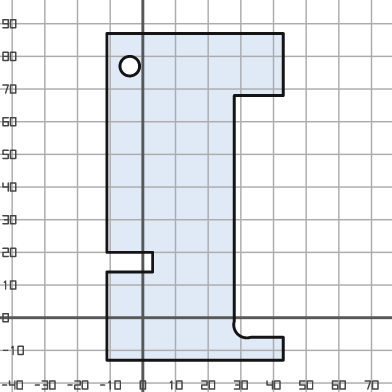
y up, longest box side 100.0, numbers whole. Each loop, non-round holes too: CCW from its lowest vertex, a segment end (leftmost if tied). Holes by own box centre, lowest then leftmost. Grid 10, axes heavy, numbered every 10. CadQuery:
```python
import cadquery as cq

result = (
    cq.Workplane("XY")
    .moveTo(-11.0, -13.0)
    .lineTo(43.0, -13.0)
    .lineTo(43.0, -6.0)
    .lineTo(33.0, -6.0)
    .threePointArc((29.0, -5.0), (28.0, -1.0))
    .lineTo(28.0, 68.0)
    .lineTo(43.0, 68.0)
    .lineTo(43.0, 87.0)
    .lineTo(-11.0, 87.0)
    .lineTo(-11.0, 20.0)
    .lineTo(3.0, 20.0)
    .lineTo(3.0, 14.0)
    .lineTo(-11.0, 14.0)
    .close()
    .moveTo(-4.0, 77.0)
    .circle(3.0)
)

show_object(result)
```